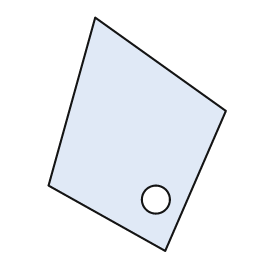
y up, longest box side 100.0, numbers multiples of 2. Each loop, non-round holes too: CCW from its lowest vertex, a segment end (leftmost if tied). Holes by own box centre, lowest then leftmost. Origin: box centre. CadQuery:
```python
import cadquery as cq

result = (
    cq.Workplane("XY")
    .moveTo(12.0, -50.0)
    .lineTo(38.0, 10.0)
    .lineTo(-18.0, 50.0)
    .lineTo(-38.0, -22.0)
    .close()
    .moveTo(8.0, -28.0)
    .circle(6.0)
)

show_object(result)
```